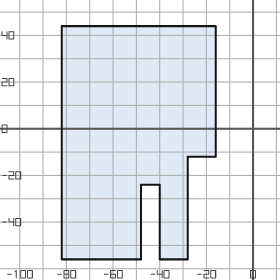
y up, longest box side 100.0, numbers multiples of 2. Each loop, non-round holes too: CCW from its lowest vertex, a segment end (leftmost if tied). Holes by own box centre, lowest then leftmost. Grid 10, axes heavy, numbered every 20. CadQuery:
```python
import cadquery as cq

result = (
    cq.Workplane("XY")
    .moveTo(-82.0, -56.0)
    .lineTo(-48.0, -56.0)
    .lineTo(-48.0, -24.0)
    .lineTo(-40.0, -24.0)
    .lineTo(-40.0, -56.0)
    .lineTo(-28.0, -56.0)
    .lineTo(-28.0, -12.0)
    .lineTo(-16.0, -12.0)
    .lineTo(-16.0, 44.0)
    .lineTo(-82.0, 44.0)
    .close()
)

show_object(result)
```